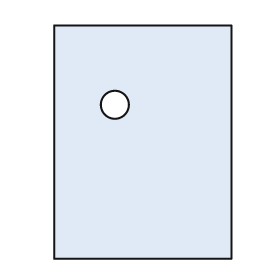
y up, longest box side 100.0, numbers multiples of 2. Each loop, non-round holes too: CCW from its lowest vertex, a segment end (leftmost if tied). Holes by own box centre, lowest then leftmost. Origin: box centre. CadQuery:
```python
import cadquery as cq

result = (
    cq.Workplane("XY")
    .moveTo(-38.0, -50.0)
    .lineTo(38.0, -50.0)
    .lineTo(38.0, 50.0)
    .lineTo(-38.0, 50.0)
    .close()
    .moveTo(-12.0, 16.0)
    .circle(6.0)
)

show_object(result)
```